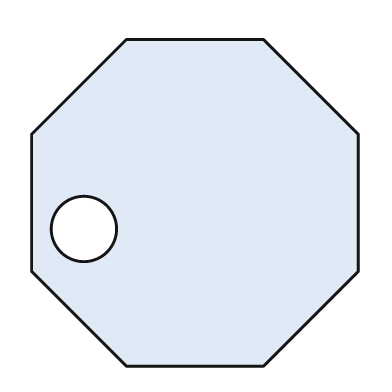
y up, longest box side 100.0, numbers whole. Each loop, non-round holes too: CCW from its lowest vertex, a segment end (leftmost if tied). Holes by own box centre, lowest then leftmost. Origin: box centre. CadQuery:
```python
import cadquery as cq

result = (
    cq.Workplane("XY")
    .moveTo(-21.0, -50.0)
    .lineTo(21.0, -50.0)
    .lineTo(50.0, -21.0)
    .lineTo(50.0, 21.0)
    .lineTo(21.0, 50.0)
    .lineTo(-21.0, 50.0)
    .lineTo(-50.0, 21.0)
    .lineTo(-50.0, -21.0)
    .close()
    .moveTo(-34.0, -8.0)
    .circle(10.0)
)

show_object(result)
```